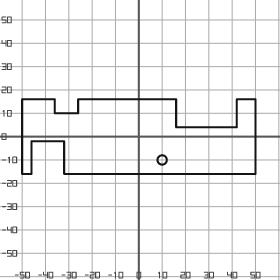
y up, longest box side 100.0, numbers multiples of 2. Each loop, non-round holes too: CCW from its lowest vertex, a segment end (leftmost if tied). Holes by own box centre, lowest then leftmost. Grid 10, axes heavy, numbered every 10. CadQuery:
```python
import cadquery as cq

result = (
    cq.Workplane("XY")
    .moveTo(-50.0, -16.0)
    .lineTo(-46.0, -16.0)
    .lineTo(-46.0, -2.0)
    .lineTo(-32.0, -2.0)
    .lineTo(-32.0, -16.0)
    .lineTo(50.0, -16.0)
    .lineTo(50.0, 16.0)
    .lineTo(42.0, 16.0)
    .lineTo(42.0, 4.0)
    .lineTo(16.0, 4.0)
    .lineTo(16.0, 16.0)
    .lineTo(-26.0, 16.0)
    .lineTo(-26.0, 10.0)
    .lineTo(-36.0, 10.0)
    .lineTo(-36.0, 16.0)
    .lineTo(-50.0, 16.0)
    .close()
    .moveTo(10.0, -10.0)
    .circle(2.0)
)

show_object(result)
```